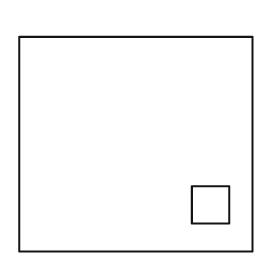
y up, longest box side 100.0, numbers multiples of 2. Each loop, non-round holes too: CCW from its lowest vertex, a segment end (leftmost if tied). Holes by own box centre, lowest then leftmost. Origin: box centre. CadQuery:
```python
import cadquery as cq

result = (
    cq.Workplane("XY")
    .moveTo(-50.0, -46.0)
    .lineTo(50.0, -46.0)
    .lineTo(50.0, 46.0)
    .lineTo(-50.0, 46.0)
    .close()
    .moveTo(24.0, -34.0)
    .lineTo(40.0, -34.0)
    .lineTo(40.0, -18.0)
    .lineTo(24.0, -18.0)
    .close()
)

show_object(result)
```